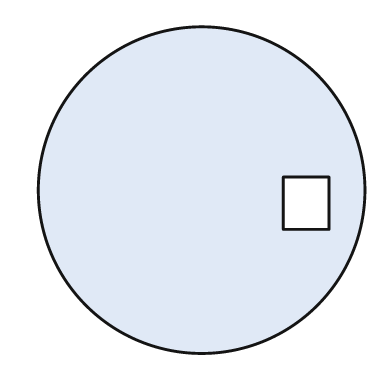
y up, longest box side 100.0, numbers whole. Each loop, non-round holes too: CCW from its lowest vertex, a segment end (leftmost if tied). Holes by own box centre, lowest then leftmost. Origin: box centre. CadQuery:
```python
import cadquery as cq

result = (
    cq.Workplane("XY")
    .moveTo(0.0, 0.0)
    .circle(50.0)
    .moveTo(25.0, -12.0)
    .lineTo(39.0, -12.0)
    .lineTo(39.0, 4.0)
    .lineTo(25.0, 4.0)
    .close()
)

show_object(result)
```